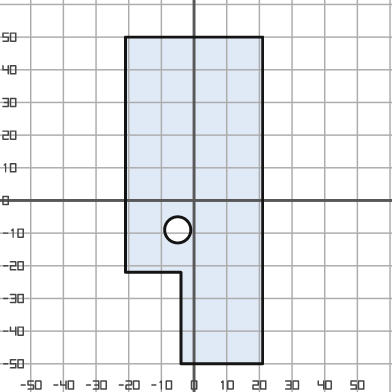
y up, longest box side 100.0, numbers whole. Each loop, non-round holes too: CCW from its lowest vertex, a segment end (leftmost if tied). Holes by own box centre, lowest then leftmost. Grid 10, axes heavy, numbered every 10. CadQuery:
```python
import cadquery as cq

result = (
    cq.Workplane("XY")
    .moveTo(-4.0, -50.0)
    .lineTo(21.0, -50.0)
    .lineTo(21.0, 50.0)
    .lineTo(-21.0, 50.0)
    .lineTo(-21.0, -22.0)
    .lineTo(-4.0, -22.0)
    .close()
    .moveTo(-5.0, -9.0)
    .circle(4.0)
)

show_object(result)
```